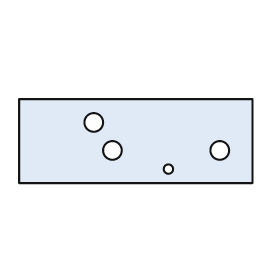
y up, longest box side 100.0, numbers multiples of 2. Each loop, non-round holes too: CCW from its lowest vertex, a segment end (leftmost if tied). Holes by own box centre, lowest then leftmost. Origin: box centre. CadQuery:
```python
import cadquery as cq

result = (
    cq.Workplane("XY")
    .moveTo(-50.0, -18.0)
    .lineTo(50.0, -18.0)
    .lineTo(50.0, 18.0)
    .lineTo(-50.0, 18.0)
    .close()
    .moveTo(14.0, -12.0)
    .circle(2.0)
    .moveTo(-10.0, -4.0)
    .circle(4.0)
    .moveTo(36.0, -4.0)
    .circle(4.0)
    .moveTo(-18.0, 8.0)
    .circle(4.0)
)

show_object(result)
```